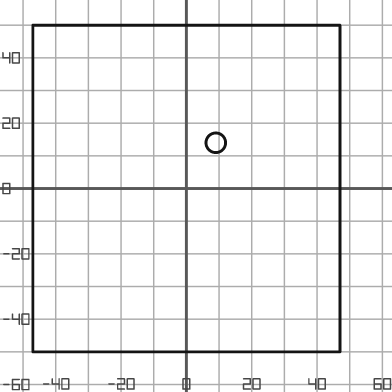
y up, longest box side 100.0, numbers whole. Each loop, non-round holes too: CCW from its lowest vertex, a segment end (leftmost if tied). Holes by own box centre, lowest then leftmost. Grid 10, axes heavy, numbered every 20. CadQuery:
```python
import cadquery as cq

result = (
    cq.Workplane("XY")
    .moveTo(-47.0, -50.0)
    .lineTo(47.0, -50.0)
    .lineTo(47.0, 50.0)
    .lineTo(-47.0, 50.0)
    .close()
    .moveTo(9.0, 14.0)
    .circle(3.0)
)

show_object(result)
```